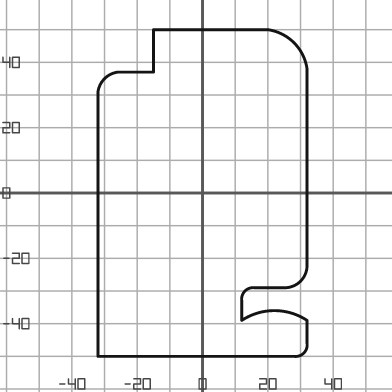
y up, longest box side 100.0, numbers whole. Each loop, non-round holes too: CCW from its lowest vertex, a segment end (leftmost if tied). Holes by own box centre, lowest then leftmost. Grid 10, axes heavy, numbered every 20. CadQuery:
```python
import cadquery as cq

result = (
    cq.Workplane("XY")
    .moveTo(-32.0, -50.0)
    .lineTo(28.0, -50.0)
    .threePointArc((31.0, -49.0), (32.0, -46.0))
    .lineTo(32.0, -39.0)
    .threePointArc((22.0, -36.0), (12.0, -39.0))
    .lineTo(12.0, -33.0)
    .threePointArc((13.0, -30.0), (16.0, -29.0))
    .lineTo(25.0, -29.0)
    .threePointArc((30.0, -27.0), (32.0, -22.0))
    .lineTo(32.0, 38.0)
    .threePointArc((28.0, 46.0), (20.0, 50.0))
    .lineTo(-15.0, 50.0)
    .lineTo(-15.0, 37.0)
    .lineTo(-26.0, 37.0)
    .threePointArc((-30.0, 35.0), (-32.0, 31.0))
    .close()
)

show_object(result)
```